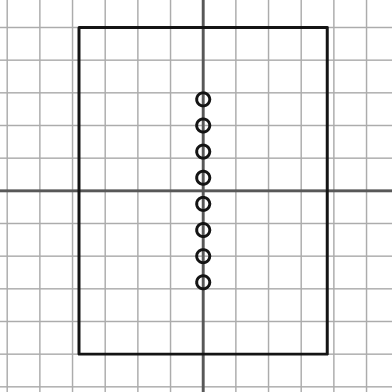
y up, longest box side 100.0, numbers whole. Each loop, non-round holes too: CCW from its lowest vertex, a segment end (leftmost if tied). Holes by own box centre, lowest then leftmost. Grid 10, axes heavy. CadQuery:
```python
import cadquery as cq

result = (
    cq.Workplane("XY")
    .moveTo(-38.0, -50.0)
    .lineTo(38.0, -50.0)
    .lineTo(38.0, 50.0)
    .lineTo(-38.0, 50.0)
    .close()
    .moveTo(0.0, -28.0)
    .circle(2.0)
    .moveTo(0.0, -20.0)
    .circle(2.0)
    .moveTo(0.0, -12.0)
    .circle(2.0)
    .moveTo(0.0, -4.0)
    .circle(2.0)
    .moveTo(0.0, 4.0)
    .circle(2.0)
    .moveTo(0.0, 12.0)
    .circle(2.0)
    .moveTo(0.0, 20.0)
    .circle(2.0)
    .moveTo(0.0, 28.0)
    .circle(2.0)
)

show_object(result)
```